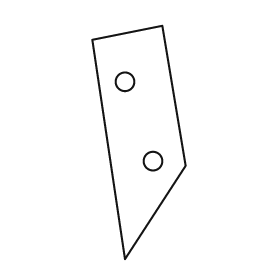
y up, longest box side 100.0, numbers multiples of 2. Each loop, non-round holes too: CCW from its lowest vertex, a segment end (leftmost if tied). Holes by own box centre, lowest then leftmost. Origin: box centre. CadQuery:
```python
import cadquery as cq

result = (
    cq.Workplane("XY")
    .moveTo(-6.0, -50.0)
    .lineTo(20.0, -10.0)
    .lineTo(10.0, 50.0)
    .lineTo(-20.0, 44.0)
    .close()
    .moveTo(6.0, -8.0)
    .circle(4.0)
    .moveTo(-6.0, 26.0)
    .circle(4.0)
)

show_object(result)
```